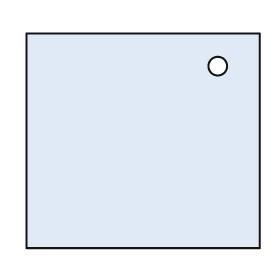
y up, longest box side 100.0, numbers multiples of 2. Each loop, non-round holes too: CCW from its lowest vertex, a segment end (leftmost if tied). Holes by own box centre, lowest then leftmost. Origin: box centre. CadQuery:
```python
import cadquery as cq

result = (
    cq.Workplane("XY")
    .moveTo(-50.0, -46.0)
    .lineTo(50.0, -46.0)
    .lineTo(50.0, 46.0)
    .lineTo(-50.0, 46.0)
    .close()
    .moveTo(32.0, 32.0)
    .circle(4.0)
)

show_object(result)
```